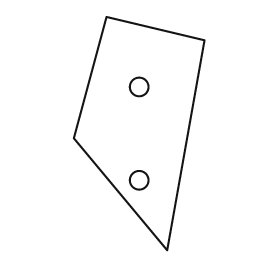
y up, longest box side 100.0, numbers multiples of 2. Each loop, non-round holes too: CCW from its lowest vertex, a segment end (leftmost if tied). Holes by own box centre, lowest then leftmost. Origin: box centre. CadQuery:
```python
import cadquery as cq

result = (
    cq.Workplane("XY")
    .moveTo(12.0, -50.0)
    .lineTo(28.0, 40.0)
    .lineTo(-14.0, 50.0)
    .lineTo(-28.0, -2.0)
    .close()
    .moveTo(0.0, -20.0)
    .circle(4.0)
    .moveTo(0.0, 20.0)
    .circle(4.0)
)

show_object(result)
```